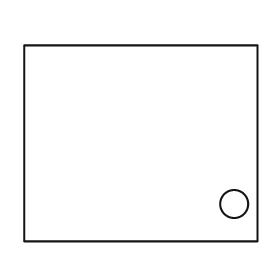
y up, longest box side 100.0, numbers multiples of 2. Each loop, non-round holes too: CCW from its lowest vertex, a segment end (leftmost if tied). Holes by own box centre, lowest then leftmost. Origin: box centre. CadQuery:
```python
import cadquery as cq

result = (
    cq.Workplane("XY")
    .moveTo(-50.0, -42.0)
    .lineTo(50.0, -42.0)
    .lineTo(50.0, 42.0)
    .lineTo(-50.0, 42.0)
    .close()
    .moveTo(40.0, -26.0)
    .circle(6.0)
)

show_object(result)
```